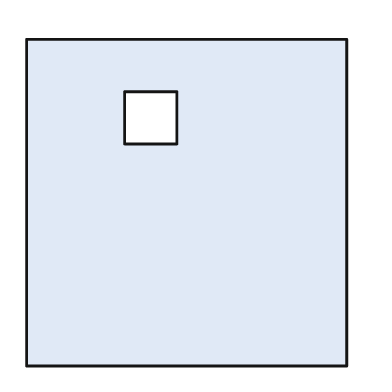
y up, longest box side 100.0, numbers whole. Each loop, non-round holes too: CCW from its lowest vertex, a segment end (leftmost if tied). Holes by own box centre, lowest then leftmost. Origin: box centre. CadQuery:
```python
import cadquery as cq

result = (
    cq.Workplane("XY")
    .moveTo(-49.0, -50.0)
    .lineTo(49.0, -50.0)
    .lineTo(49.0, 50.0)
    .lineTo(-49.0, 50.0)
    .close()
    .moveTo(-19.0, 18.0)
    .lineTo(-3.0, 18.0)
    .lineTo(-3.0, 34.0)
    .lineTo(-19.0, 34.0)
    .close()
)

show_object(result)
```